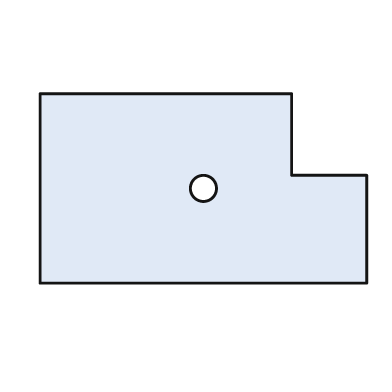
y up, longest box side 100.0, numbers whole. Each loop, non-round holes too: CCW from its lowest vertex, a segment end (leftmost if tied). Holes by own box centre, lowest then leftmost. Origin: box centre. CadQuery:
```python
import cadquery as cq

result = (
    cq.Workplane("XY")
    .moveTo(-50.0, -29.0)
    .lineTo(50.0, -29.0)
    .lineTo(50.0, 4.0)
    .lineTo(27.0, 4.0)
    .lineTo(27.0, 29.0)
    .lineTo(-50.0, 29.0)
    .close()
    .moveTo(0.0, 0.0)
    .circle(4.0)
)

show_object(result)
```